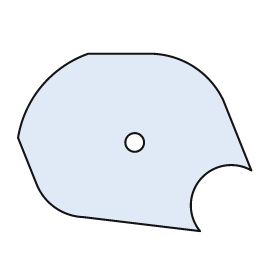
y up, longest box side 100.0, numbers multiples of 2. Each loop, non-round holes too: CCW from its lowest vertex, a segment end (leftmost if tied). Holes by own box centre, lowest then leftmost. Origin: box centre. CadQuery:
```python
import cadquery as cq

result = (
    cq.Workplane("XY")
    .moveTo(28.0, -38.0)
    .threePointArc((28.0, -16.0), (50.0, -12.0))
    .lineTo(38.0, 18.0)
    .threePointArc((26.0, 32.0), (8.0, 38.0))
    .lineTo(-20.0, 38.0)
    .threePointArc((-40.0, 24.0), (-50.0, 2.0))
    .lineTo(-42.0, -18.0)
    .threePointArc((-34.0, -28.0), (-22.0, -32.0))
    .close()
    .moveTo(0.0, 0.0)
    .circle(4.0)
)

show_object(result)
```